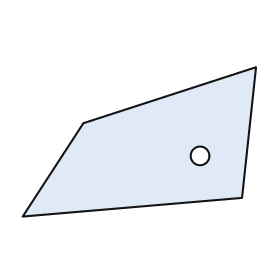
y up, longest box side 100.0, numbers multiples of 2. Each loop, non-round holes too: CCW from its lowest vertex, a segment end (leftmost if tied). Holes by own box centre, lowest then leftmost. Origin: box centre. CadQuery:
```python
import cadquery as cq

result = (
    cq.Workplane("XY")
    .moveTo(-50.0, -32.0)
    .lineTo(44.0, -24.0)
    .lineTo(50.0, 32.0)
    .lineTo(-24.0, 8.0)
    .close()
    .moveTo(26.0, -6.0)
    .circle(4.0)
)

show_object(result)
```